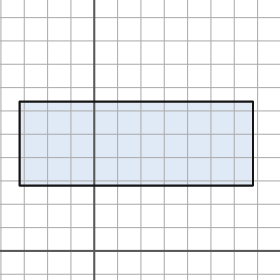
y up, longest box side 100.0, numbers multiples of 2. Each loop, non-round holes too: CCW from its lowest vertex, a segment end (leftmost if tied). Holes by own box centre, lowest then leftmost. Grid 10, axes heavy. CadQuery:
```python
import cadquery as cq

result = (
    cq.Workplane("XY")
    .moveTo(-32.0, 28.0)
    .lineTo(68.0, 28.0)
    .lineTo(68.0, 64.0)
    .lineTo(-32.0, 64.0)
    .close()
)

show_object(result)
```